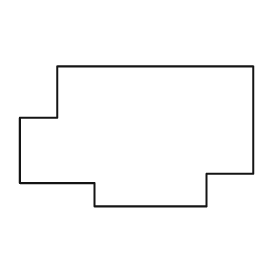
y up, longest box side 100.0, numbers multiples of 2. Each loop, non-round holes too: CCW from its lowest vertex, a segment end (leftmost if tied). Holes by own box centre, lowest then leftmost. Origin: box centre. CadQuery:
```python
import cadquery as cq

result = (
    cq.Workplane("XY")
    .moveTo(-18.0, -30.0)
    .lineTo(30.0, -30.0)
    .lineTo(30.0, -16.0)
    .lineTo(50.0, -16.0)
    .lineTo(50.0, 30.0)
    .lineTo(-34.0, 30.0)
    .lineTo(-34.0, 8.0)
    .lineTo(-50.0, 8.0)
    .lineTo(-50.0, -20.0)
    .lineTo(-18.0, -20.0)
    .close()
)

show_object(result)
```